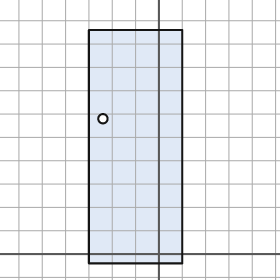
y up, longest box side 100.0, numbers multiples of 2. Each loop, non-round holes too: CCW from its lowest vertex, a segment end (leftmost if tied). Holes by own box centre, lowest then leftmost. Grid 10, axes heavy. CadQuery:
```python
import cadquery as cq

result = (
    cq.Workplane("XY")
    .moveTo(-30.0, -4.0)
    .lineTo(10.0, -4.0)
    .lineTo(10.0, 96.0)
    .lineTo(-30.0, 96.0)
    .close()
    .moveTo(-24.0, 58.0)
    .circle(2.0)
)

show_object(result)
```